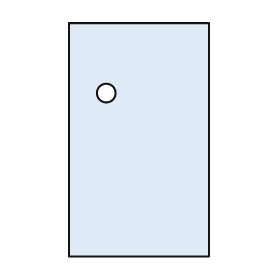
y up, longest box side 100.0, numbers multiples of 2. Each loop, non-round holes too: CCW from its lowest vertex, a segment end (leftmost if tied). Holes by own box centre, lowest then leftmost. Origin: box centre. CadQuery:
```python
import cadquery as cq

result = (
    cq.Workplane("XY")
    .moveTo(-30.0, -50.0)
    .lineTo(30.0, -50.0)
    .lineTo(30.0, 50.0)
    .lineTo(-30.0, 50.0)
    .close()
    .moveTo(-14.0, 20.0)
    .circle(4.0)
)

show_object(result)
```